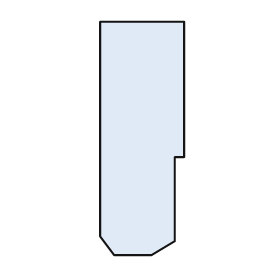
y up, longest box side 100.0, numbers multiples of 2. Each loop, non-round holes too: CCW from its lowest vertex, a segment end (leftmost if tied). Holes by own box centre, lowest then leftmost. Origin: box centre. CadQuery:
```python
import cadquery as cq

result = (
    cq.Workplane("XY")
    .moveTo(-12.0, -50.0)
    .lineTo(4.0, -50.0)
    .lineTo(14.0, -44.0)
    .lineTo(14.0, -8.0)
    .lineTo(18.0, -8.0)
    .lineTo(18.0, 50.0)
    .lineTo(-18.0, 50.0)
    .lineTo(-18.0, -42.0)
    .close()
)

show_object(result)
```